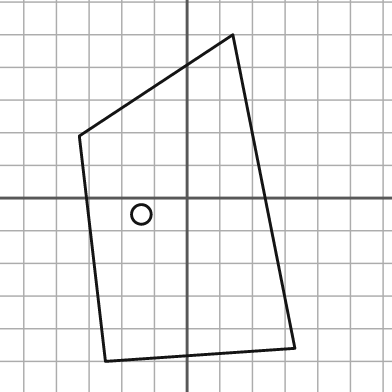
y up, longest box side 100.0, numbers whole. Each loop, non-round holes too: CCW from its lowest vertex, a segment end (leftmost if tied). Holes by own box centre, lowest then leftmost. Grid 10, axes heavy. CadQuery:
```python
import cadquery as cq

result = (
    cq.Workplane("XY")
    .moveTo(-25.0, -50.0)
    .lineTo(33.0, -46.0)
    .lineTo(14.0, 50.0)
    .lineTo(-33.0, 19.0)
    .close()
    .moveTo(-14.0, -5.0)
    .circle(3.0)
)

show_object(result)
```